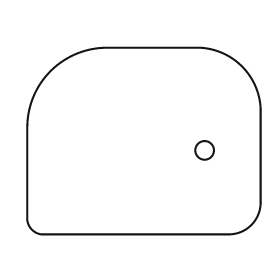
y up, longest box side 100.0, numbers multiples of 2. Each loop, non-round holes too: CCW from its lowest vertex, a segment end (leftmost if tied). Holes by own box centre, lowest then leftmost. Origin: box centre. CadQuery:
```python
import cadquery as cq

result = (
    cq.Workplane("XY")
    .moveTo(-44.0, -40.0)
    .lineTo(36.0, -40.0)
    .threePointArc((46.0, -36.0), (50.0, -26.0))
    .lineTo(50.0, 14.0)
    .threePointArc((42.0, 32.0), (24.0, 40.0))
    .lineTo(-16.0, 40.0)
    .threePointArc((-40.0, 30.0), (-50.0, 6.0))
    .lineTo(-50.0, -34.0)
    .threePointArc((-48.0, -38.0), (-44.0, -40.0))
    .close()
    .moveTo(26.0, -4.0)
    .circle(4.0)
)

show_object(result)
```